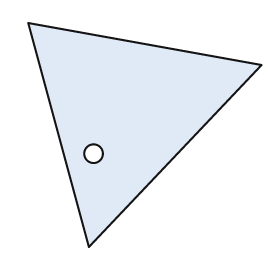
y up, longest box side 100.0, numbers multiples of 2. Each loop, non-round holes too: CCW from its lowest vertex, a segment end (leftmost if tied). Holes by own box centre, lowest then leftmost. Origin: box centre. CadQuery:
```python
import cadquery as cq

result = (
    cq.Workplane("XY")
    .moveTo(-24.0, -48.0)
    .lineTo(50.0, 30.0)
    .lineTo(-50.0, 48.0)
    .close()
    .moveTo(-22.0, -8.0)
    .circle(4.0)
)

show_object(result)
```